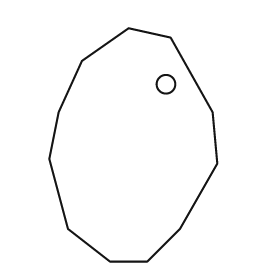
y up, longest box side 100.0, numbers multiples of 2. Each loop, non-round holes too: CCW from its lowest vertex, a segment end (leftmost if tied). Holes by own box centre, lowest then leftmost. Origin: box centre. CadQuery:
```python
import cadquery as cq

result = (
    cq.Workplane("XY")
    .moveTo(-10.0, -50.0)
    .lineTo(6.0, -50.0)
    .lineTo(20.0, -36.0)
    .lineTo(36.0, -8.0)
    .lineTo(34.0, 14.0)
    .lineTo(16.0, 46.0)
    .lineTo(-2.0, 50.0)
    .lineTo(-22.0, 36.0)
    .lineTo(-32.0, 14.0)
    .lineTo(-36.0, -6.0)
    .lineTo(-28.0, -36.0)
    .close()
    .moveTo(14.0, 26.0)
    .circle(4.0)
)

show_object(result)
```